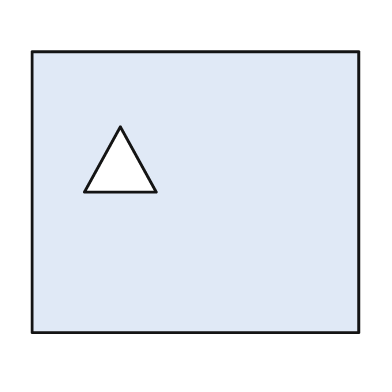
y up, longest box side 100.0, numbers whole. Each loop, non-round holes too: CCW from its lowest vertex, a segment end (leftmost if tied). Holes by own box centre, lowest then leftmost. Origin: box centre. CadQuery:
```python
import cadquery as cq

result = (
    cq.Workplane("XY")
    .moveTo(-50.0, -43.0)
    .lineTo(50.0, -43.0)
    .lineTo(50.0, 43.0)
    .lineTo(-50.0, 43.0)
    .close()
    .moveTo(-34.0, 0.0)
    .lineTo(-12.0, 0.0)
    .lineTo(-23.0, 20.0)
    .close()
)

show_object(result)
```